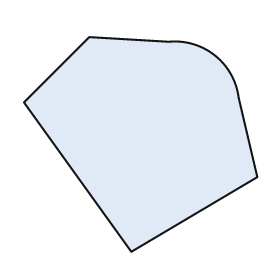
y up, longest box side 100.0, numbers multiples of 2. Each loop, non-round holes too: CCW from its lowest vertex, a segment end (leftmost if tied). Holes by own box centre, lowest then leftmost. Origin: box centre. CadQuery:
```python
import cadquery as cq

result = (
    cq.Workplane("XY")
    .moveTo(-4.0, -46.0)
    .lineTo(50.0, -14.0)
    .lineTo(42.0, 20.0)
    .threePointArc((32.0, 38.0), (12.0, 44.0))
    .lineTo(-22.0, 46.0)
    .lineTo(-50.0, 18.0)
    .close()
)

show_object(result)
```